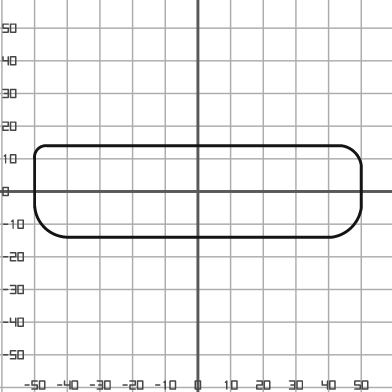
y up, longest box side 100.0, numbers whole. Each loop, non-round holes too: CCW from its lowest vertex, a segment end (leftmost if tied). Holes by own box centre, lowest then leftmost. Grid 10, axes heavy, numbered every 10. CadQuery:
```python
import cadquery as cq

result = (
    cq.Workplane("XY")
    .moveTo(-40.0, -14.0)
    .lineTo(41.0, -14.0)
    .threePointArc((47.0, -11.0), (50.0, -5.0))
    .lineTo(50.0, 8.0)
    .threePointArc((48.0, 12.0), (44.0, 14.0))
    .lineTo(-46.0, 14.0)
    .threePointArc((-49.0, 13.0), (-50.0, 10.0))
    .lineTo(-50.0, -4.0)
    .threePointArc((-47.0, -11.0), (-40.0, -14.0))
    .close()
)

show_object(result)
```